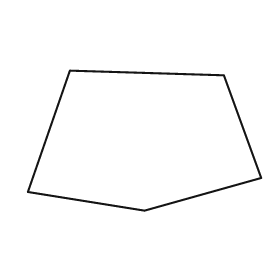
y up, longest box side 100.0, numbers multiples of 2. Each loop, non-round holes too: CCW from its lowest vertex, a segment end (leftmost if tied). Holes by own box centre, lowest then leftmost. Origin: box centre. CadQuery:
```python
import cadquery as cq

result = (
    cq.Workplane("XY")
    .moveTo(0.0, -30.0)
    .lineTo(50.0, -16.0)
    .lineTo(34.0, 28.0)
    .lineTo(-32.0, 30.0)
    .lineTo(-50.0, -22.0)
    .close()
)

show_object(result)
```